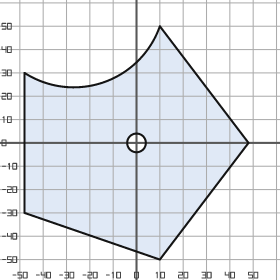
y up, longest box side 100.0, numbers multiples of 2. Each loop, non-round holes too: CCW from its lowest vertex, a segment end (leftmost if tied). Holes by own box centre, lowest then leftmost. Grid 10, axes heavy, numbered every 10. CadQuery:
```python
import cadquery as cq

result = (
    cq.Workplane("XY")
    .moveTo(10.0, -50.0)
    .lineTo(48.0, 0.0)
    .lineTo(10.0, 50.0)
    .threePointArc((-14.0, 26.0), (-48.0, 30.0))
    .lineTo(-48.0, -30.0)
    .close()
    .moveTo(0.0, 0.0)
    .circle(4.0)
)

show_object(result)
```